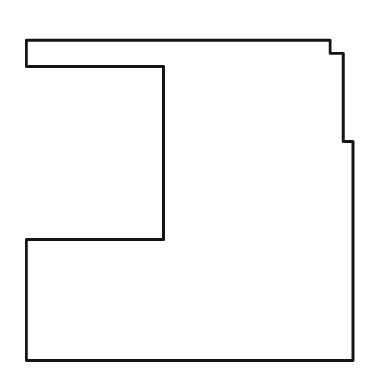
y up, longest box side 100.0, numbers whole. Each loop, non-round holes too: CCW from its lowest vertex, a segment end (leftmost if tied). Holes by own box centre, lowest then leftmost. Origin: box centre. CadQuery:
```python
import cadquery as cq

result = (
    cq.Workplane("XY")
    .moveTo(-50.0, -49.0)
    .lineTo(50.0, -49.0)
    .lineTo(50.0, 18.0)
    .lineTo(47.0, 18.0)
    .lineTo(47.0, 45.0)
    .lineTo(43.0, 45.0)
    .lineTo(43.0, 49.0)
    .lineTo(-50.0, 49.0)
    .lineTo(-50.0, 41.0)
    .lineTo(-8.0, 41.0)
    .lineTo(-8.0, -12.0)
    .lineTo(-50.0, -12.0)
    .close()
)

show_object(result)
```